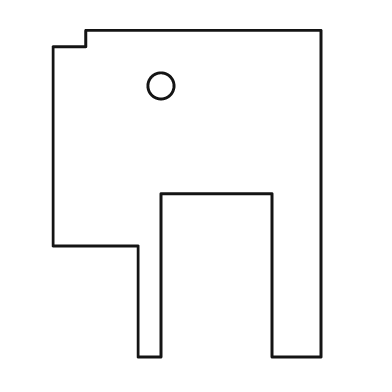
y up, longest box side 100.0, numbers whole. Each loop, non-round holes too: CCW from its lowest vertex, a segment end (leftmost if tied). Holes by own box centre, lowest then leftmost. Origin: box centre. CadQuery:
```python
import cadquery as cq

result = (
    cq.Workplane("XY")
    .moveTo(-15.0, -50.0)
    .lineTo(-8.0, -50.0)
    .lineTo(-8.0, 0.0)
    .lineTo(26.0, 0.0)
    .lineTo(26.0, -50.0)
    .lineTo(41.0, -50.0)
    .lineTo(41.0, 50.0)
    .lineTo(-31.0, 50.0)
    .lineTo(-31.0, 45.0)
    .lineTo(-41.0, 45.0)
    .lineTo(-41.0, -16.0)
    .lineTo(-15.0, -16.0)
    .close()
    .moveTo(-8.0, 33.0)
    .circle(4.0)
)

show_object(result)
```